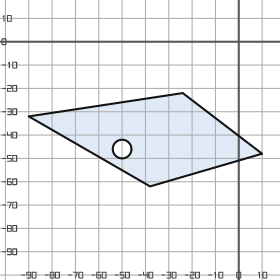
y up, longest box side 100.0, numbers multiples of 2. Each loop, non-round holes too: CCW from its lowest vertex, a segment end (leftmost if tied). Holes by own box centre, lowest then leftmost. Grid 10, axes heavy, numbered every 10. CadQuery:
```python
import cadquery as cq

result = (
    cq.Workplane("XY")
    .moveTo(-38.0, -62.0)
    .lineTo(10.0, -48.0)
    .lineTo(-24.0, -22.0)
    .lineTo(-90.0, -32.0)
    .close()
    .moveTo(-50.0, -46.0)
    .circle(4.0)
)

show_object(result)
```